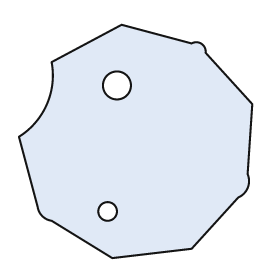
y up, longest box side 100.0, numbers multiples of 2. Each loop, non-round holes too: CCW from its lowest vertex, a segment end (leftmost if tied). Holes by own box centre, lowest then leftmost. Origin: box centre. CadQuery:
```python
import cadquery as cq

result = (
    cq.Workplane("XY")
    .moveTo(-10.0, -50.0)
    .lineTo(24.0, -46.0)
    .lineTo(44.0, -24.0)
    .threePointArc((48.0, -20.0), (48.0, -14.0))
    .lineTo(50.0, 16.0)
    .lineTo(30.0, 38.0)
    .threePointArc((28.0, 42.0), (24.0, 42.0))
    .lineTo(-6.0, 50.0)
    .lineTo(-36.0, 34.0)
    .threePointArc((-38.0, 16.0), (-50.0, 2.0))
    .lineTo(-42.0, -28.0)
    .threePointArc((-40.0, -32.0), (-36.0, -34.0))
    .close()
    .moveTo(-12.0, -30.0)
    .circle(4.0)
    .moveTo(-8.0, 24.0)
    .circle(6.0)
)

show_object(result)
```